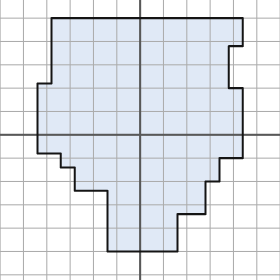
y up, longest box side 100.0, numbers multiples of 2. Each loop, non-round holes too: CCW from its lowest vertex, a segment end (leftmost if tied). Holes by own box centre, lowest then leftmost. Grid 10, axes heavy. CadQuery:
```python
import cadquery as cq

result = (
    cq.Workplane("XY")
    .moveTo(-14.0, -50.0)
    .lineTo(16.0, -50.0)
    .lineTo(16.0, -34.0)
    .lineTo(28.0, -34.0)
    .lineTo(28.0, -20.0)
    .lineTo(34.0, -20.0)
    .lineTo(34.0, -10.0)
    .lineTo(44.0, -10.0)
    .lineTo(44.0, 20.0)
    .lineTo(38.0, 20.0)
    .lineTo(38.0, 38.0)
    .lineTo(44.0, 38.0)
    .lineTo(44.0, 50.0)
    .lineTo(-38.0, 50.0)
    .lineTo(-38.0, 22.0)
    .lineTo(-44.0, 22.0)
    .lineTo(-44.0, -8.0)
    .lineTo(-34.0, -8.0)
    .lineTo(-34.0, -14.0)
    .lineTo(-28.0, -14.0)
    .lineTo(-28.0, -24.0)
    .lineTo(-14.0, -24.0)
    .close()
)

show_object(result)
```